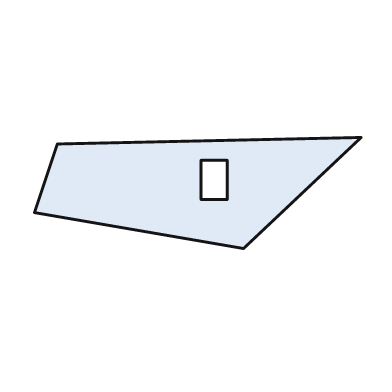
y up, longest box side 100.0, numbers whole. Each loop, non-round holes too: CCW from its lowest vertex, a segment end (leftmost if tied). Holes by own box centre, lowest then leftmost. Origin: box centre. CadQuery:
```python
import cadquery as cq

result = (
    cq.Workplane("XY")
    .moveTo(14.0, -17.0)
    .lineTo(50.0, 17.0)
    .lineTo(-43.0, 15.0)
    .lineTo(-50.0, -6.0)
    .close()
    .moveTo(1.0, -2.0)
    .lineTo(9.0, -2.0)
    .lineTo(9.0, 10.0)
    .lineTo(1.0, 10.0)
    .close()
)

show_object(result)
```